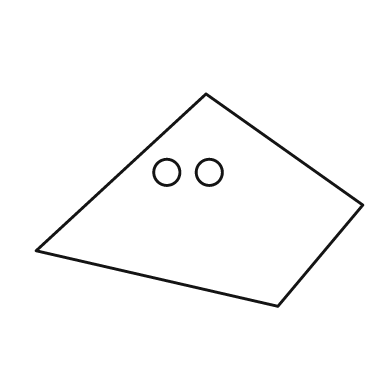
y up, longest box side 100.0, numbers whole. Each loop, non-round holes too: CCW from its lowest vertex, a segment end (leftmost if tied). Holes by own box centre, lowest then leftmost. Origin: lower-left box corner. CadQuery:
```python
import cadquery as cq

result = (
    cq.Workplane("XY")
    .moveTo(74.0, 0.0)
    .lineTo(100.0, 31.0)
    .lineTo(52.0, 65.0)
    .lineTo(0.0, 17.0)
    .close()
    .moveTo(40.0, 41.0)
    .circle(4.0)
    .moveTo(53.0, 41.0)
    .circle(4.0)
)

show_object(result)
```